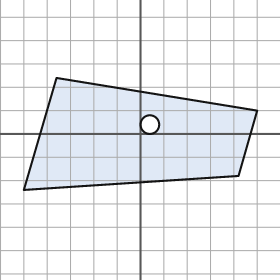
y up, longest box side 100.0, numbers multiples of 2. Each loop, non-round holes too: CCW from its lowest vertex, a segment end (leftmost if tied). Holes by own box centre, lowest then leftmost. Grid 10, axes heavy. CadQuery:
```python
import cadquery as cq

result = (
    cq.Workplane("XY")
    .moveTo(-50.0, -24.0)
    .lineTo(42.0, -18.0)
    .lineTo(50.0, 10.0)
    .lineTo(-36.0, 24.0)
    .close()
    .moveTo(4.0, 4.0)
    .circle(4.0)
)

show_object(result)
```